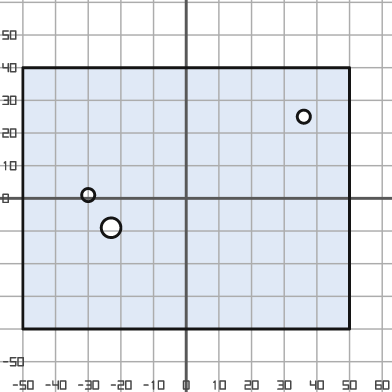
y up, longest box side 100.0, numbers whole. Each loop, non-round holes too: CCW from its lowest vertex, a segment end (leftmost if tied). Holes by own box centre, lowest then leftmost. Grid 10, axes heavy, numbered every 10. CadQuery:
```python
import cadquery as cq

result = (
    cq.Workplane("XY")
    .moveTo(-50.0, -40.0)
    .lineTo(50.0, -40.0)
    .lineTo(50.0, 40.0)
    .lineTo(-50.0, 40.0)
    .close()
    .moveTo(-23.0, -9.0)
    .circle(3.0)
    .moveTo(-30.0, 1.0)
    .circle(2.0)
    .moveTo(36.0, 25.0)
    .circle(2.0)
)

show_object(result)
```